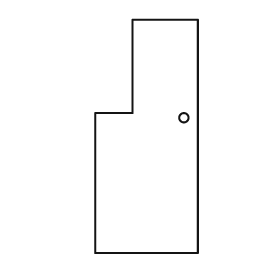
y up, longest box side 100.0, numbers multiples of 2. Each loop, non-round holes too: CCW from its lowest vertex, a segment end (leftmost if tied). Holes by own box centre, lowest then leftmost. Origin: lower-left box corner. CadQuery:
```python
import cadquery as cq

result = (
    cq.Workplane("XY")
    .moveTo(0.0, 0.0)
    .lineTo(44.0, 0.0)
    .lineTo(44.0, 100.0)
    .lineTo(16.0, 100.0)
    .lineTo(16.0, 60.0)
    .lineTo(0.0, 60.0)
    .close()
    .moveTo(38.0, 58.0)
    .circle(2.0)
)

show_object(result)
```